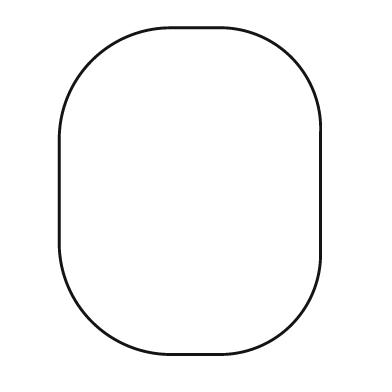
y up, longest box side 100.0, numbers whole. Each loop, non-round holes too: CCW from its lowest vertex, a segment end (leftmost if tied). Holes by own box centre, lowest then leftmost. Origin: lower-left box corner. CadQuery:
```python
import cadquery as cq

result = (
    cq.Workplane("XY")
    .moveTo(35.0, 0.0)
    .lineTo(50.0, 0.0)
    .threePointArc((71.0, 9.0), (80.0, 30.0))
    .lineTo(80.0, 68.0)
    .threePointArc((71.0, 91.0), (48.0, 100.0))
    .lineTo(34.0, 100.0)
    .threePointArc((10.0, 90.0), (0.0, 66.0))
    .lineTo(0.0, 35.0)
    .threePointArc((10.0, 10.0), (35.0, 0.0))
    .close()
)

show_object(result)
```